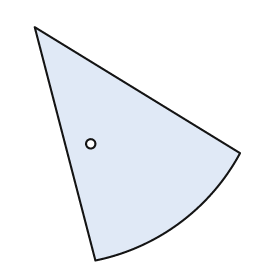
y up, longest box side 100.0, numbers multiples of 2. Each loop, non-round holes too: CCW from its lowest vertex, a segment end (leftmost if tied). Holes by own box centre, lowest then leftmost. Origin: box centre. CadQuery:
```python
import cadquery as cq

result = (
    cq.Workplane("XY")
    .moveTo(-18.0, -50.0)
    .threePointArc((18.0, -34.0), (44.0, -4.0))
    .lineTo(-44.0, 50.0)
    .close()
    .moveTo(-20.0, 0.0)
    .circle(2.0)
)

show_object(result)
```